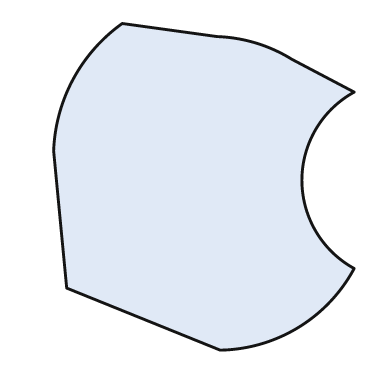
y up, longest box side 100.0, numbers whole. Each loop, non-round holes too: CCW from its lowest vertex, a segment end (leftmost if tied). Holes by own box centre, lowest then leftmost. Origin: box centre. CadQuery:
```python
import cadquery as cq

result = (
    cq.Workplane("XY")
    .moveTo(5.0, -50.0)
    .threePointArc((29.0, -43.0), (46.0, -25.0))
    .threePointArc((30.0, 2.0), (46.0, 29.0))
    .lineTo(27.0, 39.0)
    .threePointArc((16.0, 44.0), (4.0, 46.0))
    .lineTo(-25.0, 50.0)
    .threePointArc((-40.0, 33.0), (-46.0, 11.0))
    .lineTo(-42.0, -31.0)
    .close()
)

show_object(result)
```